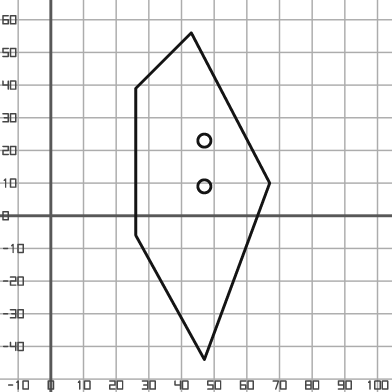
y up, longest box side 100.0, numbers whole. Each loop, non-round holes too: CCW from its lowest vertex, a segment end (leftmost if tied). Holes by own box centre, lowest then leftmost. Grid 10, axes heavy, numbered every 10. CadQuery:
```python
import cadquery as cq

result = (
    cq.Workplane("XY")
    .moveTo(47.0, -44.0)
    .lineTo(67.0, 10.0)
    .lineTo(43.0, 56.0)
    .lineTo(26.0, 39.0)
    .lineTo(26.0, -6.0)
    .close()
    .moveTo(47.0, 9.0)
    .circle(2.0)
    .moveTo(47.0, 23.0)
    .circle(2.0)
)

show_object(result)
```